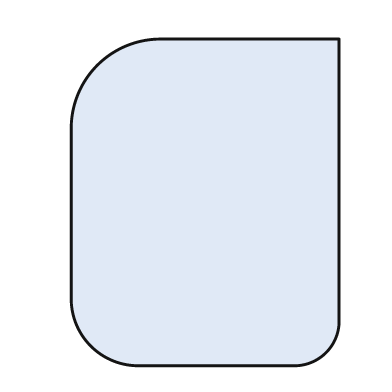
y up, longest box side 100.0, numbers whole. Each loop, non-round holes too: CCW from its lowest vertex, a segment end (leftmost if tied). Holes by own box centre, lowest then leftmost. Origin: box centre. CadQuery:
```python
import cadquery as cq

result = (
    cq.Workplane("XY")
    .moveTo(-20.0, -50.0)
    .lineTo(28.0, -50.0)
    .threePointArc((37.0, -46.0), (41.0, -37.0))
    .lineTo(41.0, 50.0)
    .lineTo(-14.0, 50.0)
    .threePointArc((-33.0, 42.0), (-41.0, 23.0))
    .lineTo(-41.0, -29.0)
    .threePointArc((-35.0, -44.0), (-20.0, -50.0))
    .close()
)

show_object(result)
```